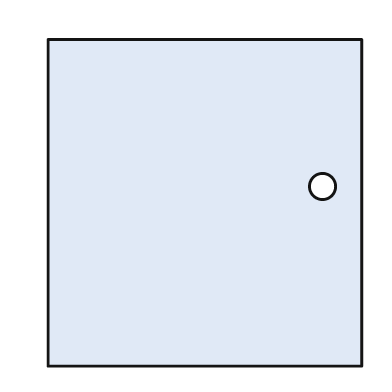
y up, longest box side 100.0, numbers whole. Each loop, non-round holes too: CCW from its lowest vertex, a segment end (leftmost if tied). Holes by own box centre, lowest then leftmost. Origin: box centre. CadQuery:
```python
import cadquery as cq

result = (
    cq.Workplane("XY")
    .moveTo(-48.0, -50.0)
    .lineTo(48.0, -50.0)
    .lineTo(48.0, 50.0)
    .lineTo(-48.0, 50.0)
    .close()
    .moveTo(36.0, 5.0)
    .circle(4.0)
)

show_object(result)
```